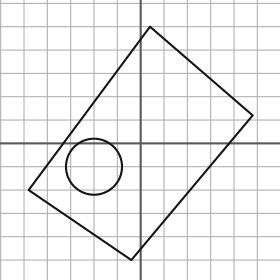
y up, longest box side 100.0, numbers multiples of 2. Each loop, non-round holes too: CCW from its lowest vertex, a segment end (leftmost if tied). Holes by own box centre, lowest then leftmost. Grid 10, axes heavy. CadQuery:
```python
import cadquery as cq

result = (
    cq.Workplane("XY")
    .moveTo(-4.0, -50.0)
    .lineTo(48.0, 12.0)
    .lineTo(4.0, 50.0)
    .lineTo(-48.0, -20.0)
    .close()
    .moveTo(-20.0, -10.0)
    .circle(12.0)
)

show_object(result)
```